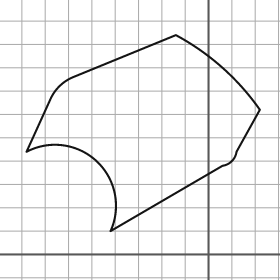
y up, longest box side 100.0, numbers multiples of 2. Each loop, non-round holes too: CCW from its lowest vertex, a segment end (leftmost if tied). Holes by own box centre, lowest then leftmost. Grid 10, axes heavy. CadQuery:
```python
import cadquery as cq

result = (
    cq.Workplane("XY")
    .moveTo(-42.0, 10.0)
    .lineTo(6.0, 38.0)
    .threePointArc((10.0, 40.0), (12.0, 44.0))
    .lineTo(22.0, 62.0)
    .threePointArc((6.0, 80.0), (-14.0, 94.0))
    .lineTo(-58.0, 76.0)
    .threePointArc((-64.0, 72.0), (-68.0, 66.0))
    .lineTo(-78.0, 44.0)
    .threePointArc((-48.0, 40.0), (-42.0, 10.0))
    .close()
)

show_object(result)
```